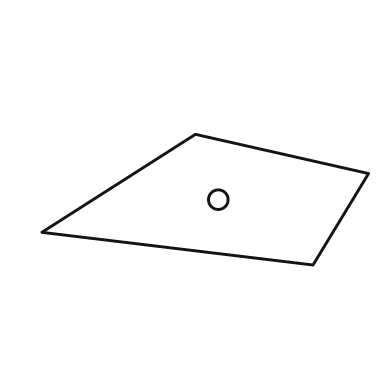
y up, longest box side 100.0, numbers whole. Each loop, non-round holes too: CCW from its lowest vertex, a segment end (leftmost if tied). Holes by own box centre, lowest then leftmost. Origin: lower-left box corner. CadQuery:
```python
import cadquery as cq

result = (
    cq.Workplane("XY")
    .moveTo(83.0, 0.0)
    .lineTo(100.0, 28.0)
    .lineTo(47.0, 40.0)
    .lineTo(0.0, 10.0)
    .close()
    .moveTo(54.0, 20.0)
    .circle(3.0)
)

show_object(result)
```